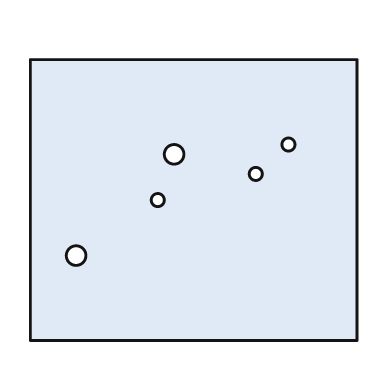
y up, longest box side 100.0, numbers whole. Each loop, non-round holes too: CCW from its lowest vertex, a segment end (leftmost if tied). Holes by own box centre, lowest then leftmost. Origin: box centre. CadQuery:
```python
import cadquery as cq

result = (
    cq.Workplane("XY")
    .moveTo(-50.0, -43.0)
    .lineTo(50.0, -43.0)
    .lineTo(50.0, 43.0)
    .lineTo(-50.0, 43.0)
    .close()
    .moveTo(-36.0, -17.0)
    .circle(3.0)
    .moveTo(-11.0, 0.0)
    .circle(2.0)
    .moveTo(19.0, 8.0)
    .circle(2.0)
    .moveTo(-6.0, 14.0)
    .circle(3.0)
    .moveTo(29.0, 17.0)
    .circle(2.0)
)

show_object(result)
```